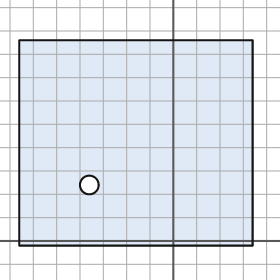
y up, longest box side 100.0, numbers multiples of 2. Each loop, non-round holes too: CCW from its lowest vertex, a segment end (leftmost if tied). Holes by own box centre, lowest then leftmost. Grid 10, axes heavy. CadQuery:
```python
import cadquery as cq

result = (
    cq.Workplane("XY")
    .moveTo(-66.0, -2.0)
    .lineTo(34.0, -2.0)
    .lineTo(34.0, 86.0)
    .lineTo(-66.0, 86.0)
    .close()
    .moveTo(-36.0, 24.0)
    .circle(4.0)
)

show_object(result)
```